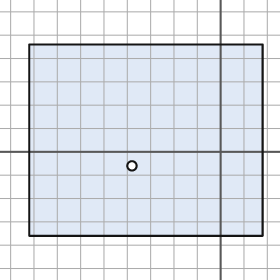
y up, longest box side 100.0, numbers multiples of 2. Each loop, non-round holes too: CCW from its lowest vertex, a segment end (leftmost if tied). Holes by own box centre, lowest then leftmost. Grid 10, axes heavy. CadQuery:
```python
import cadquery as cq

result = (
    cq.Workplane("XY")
    .moveTo(-82.0, -36.0)
    .lineTo(18.0, -36.0)
    .lineTo(18.0, 46.0)
    .lineTo(-82.0, 46.0)
    .close()
    .moveTo(-38.0, -6.0)
    .circle(2.0)
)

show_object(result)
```